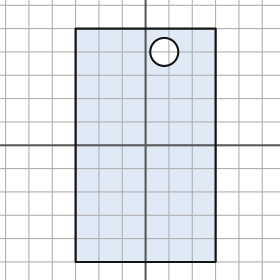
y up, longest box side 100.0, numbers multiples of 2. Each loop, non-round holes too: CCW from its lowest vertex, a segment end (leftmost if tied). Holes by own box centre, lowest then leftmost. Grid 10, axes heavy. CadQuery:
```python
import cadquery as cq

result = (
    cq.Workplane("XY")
    .moveTo(-30.0, -50.0)
    .lineTo(30.0, -50.0)
    .lineTo(30.0, 50.0)
    .lineTo(-30.0, 50.0)
    .close()
    .moveTo(8.0, 40.0)
    .circle(6.0)
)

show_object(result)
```